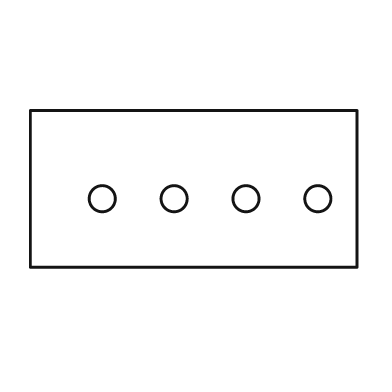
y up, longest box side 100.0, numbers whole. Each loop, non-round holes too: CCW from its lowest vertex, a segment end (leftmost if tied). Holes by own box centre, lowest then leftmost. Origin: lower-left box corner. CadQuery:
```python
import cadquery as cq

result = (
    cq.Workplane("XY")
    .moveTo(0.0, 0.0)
    .lineTo(100.0, 0.0)
    .lineTo(100.0, 48.0)
    .lineTo(0.0, 48.0)
    .close()
    .moveTo(22.0, 21.0)
    .circle(4.0)
    .moveTo(44.0, 21.0)
    .circle(4.0)
    .moveTo(66.0, 21.0)
    .circle(4.0)
    .moveTo(88.0, 21.0)
    .circle(4.0)
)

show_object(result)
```